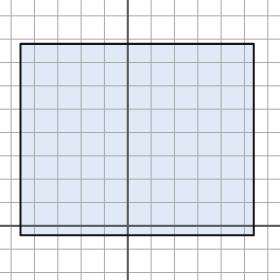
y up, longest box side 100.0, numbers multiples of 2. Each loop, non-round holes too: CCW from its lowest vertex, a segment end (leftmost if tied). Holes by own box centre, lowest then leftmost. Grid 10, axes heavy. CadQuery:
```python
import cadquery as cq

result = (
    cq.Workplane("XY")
    .moveTo(-46.0, -4.0)
    .lineTo(54.0, -4.0)
    .lineTo(54.0, 78.0)
    .lineTo(-46.0, 78.0)
    .close()
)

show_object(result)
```